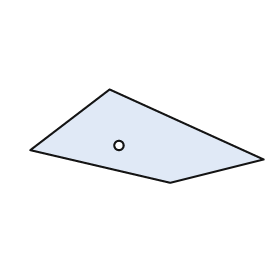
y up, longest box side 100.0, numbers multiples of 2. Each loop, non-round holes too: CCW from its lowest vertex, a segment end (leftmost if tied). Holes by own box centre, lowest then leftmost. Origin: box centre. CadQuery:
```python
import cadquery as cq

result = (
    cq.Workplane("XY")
    .moveTo(10.0, -20.0)
    .lineTo(50.0, -10.0)
    .lineTo(-16.0, 20.0)
    .lineTo(-50.0, -6.0)
    .close()
    .moveTo(-12.0, -4.0)
    .circle(2.0)
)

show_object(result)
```